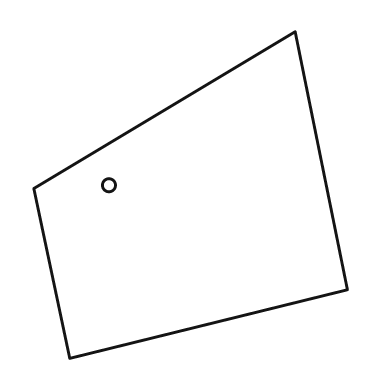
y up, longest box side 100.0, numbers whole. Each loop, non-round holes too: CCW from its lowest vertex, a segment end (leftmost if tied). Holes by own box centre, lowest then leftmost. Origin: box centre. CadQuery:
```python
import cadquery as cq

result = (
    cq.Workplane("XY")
    .moveTo(-37.0, -50.0)
    .lineTo(48.0, -29.0)
    .lineTo(32.0, 50.0)
    .lineTo(-48.0, 2.0)
    .close()
    .moveTo(-25.0, 3.0)
    .circle(2.0)
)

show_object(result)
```